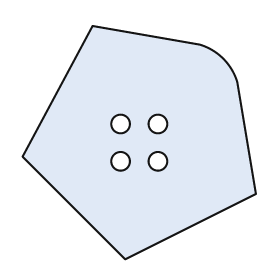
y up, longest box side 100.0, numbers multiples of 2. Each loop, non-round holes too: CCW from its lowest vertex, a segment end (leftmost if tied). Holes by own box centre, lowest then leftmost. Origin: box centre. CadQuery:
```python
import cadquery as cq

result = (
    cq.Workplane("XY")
    .moveTo(-6.0, -50.0)
    .lineTo(50.0, -22.0)
    .lineTo(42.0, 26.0)
    .threePointArc((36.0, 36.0), (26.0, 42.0))
    .lineTo(-20.0, 50.0)
    .lineTo(-50.0, -6.0)
    .close()
    .moveTo(-8.0, -8.0)
    .circle(4.0)
    .moveTo(8.0, -8.0)
    .circle(4.0)
    .moveTo(-8.0, 8.0)
    .circle(4.0)
    .moveTo(8.0, 8.0)
    .circle(4.0)
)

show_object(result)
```